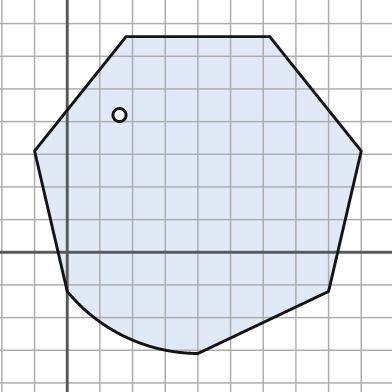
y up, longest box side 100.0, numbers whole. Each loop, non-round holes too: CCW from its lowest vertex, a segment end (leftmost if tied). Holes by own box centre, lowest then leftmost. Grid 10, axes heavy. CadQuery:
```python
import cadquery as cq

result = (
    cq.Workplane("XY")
    .moveTo(40.0, -31.0)
    .lineTo(80.0, -12.0)
    .lineTo(90.0, 31.0)
    .lineTo(62.0, 66.0)
    .lineTo(18.0, 66.0)
    .lineTo(-10.0, 31.0)
    .lineTo(0.0, -12.0)
    .threePointArc((18.0, -26.0), (40.0, -31.0))
    .close()
    .moveTo(16.0, 42.0)
    .circle(2.0)
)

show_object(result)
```